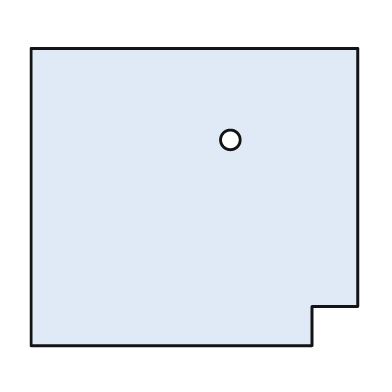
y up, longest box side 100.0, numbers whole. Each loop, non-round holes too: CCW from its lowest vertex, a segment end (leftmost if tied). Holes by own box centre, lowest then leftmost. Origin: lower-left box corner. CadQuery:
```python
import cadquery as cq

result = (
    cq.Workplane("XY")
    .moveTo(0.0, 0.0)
    .lineTo(86.0, 0.0)
    .lineTo(86.0, 12.0)
    .lineTo(100.0, 12.0)
    .lineTo(100.0, 91.0)
    .lineTo(0.0, 91.0)
    .close()
    .moveTo(61.0, 63.0)
    .circle(3.0)
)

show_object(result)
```